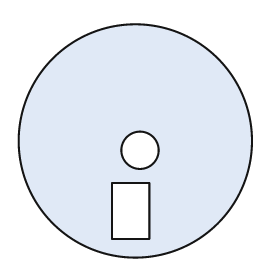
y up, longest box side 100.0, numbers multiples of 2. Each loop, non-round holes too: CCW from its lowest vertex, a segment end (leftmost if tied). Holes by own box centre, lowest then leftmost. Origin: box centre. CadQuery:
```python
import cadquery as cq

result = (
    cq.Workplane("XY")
    .moveTo(0.0, 0.0)
    .circle(50.0)
    .moveTo(-10.0, -42.0)
    .lineTo(6.0, -42.0)
    .lineTo(6.0, -18.0)
    .lineTo(-10.0, -18.0)
    .close()
    .moveTo(2.0, -4.0)
    .circle(8.0)
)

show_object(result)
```